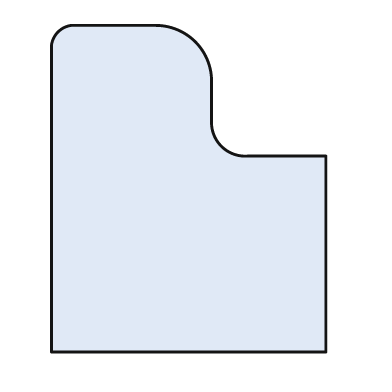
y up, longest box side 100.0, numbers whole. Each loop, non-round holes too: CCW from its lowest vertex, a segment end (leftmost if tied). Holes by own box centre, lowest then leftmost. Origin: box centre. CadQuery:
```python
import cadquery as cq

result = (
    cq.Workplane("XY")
    .moveTo(-42.0, -50.0)
    .lineTo(42.0, -50.0)
    .lineTo(42.0, 10.0)
    .lineTo(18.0, 10.0)
    .threePointArc((10.0, 13.0), (7.0, 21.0))
    .lineTo(7.0, 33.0)
    .threePointArc((2.0, 45.0), (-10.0, 50.0))
    .lineTo(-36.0, 50.0)
    .threePointArc((-40.0, 48.0), (-42.0, 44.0))
    .close()
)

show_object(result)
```